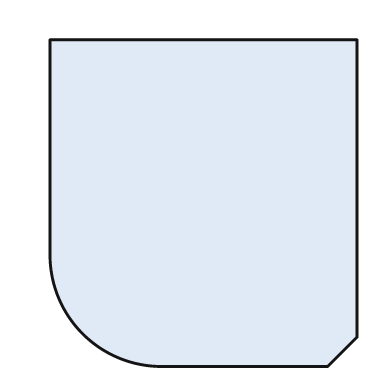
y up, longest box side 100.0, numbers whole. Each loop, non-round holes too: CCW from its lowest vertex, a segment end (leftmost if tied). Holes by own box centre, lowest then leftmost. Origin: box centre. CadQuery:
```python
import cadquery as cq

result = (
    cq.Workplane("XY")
    .moveTo(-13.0, -50.0)
    .lineTo(38.0, -50.0)
    .lineTo(47.0, -41.0)
    .lineTo(47.0, 50.0)
    .lineTo(-47.0, 50.0)
    .lineTo(-47.0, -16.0)
    .threePointArc((-37.0, -40.0), (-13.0, -50.0))
    .close()
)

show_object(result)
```